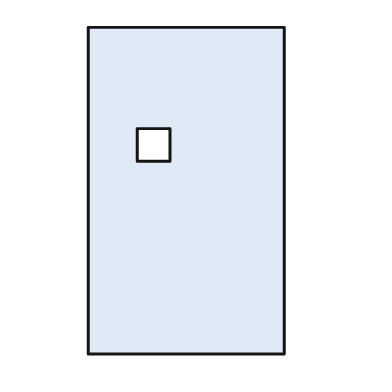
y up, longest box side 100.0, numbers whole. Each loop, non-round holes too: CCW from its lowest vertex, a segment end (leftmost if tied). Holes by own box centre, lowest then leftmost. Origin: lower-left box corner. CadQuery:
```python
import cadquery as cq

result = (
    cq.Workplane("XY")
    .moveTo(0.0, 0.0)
    .lineTo(60.0, 0.0)
    .lineTo(60.0, 100.0)
    .lineTo(0.0, 100.0)
    .close()
    .moveTo(15.0, 59.0)
    .lineTo(25.0, 59.0)
    .lineTo(25.0, 69.0)
    .lineTo(15.0, 69.0)
    .close()
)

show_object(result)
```